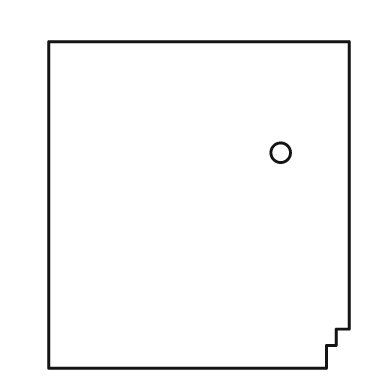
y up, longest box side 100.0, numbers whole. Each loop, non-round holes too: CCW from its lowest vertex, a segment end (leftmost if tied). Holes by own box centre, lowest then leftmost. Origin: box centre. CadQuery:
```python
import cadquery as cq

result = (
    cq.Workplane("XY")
    .moveTo(-46.0, -50.0)
    .lineTo(39.0, -50.0)
    .lineTo(39.0, -43.0)
    .lineTo(42.0, -43.0)
    .lineTo(42.0, -38.0)
    .lineTo(46.0, -38.0)
    .lineTo(46.0, 50.0)
    .lineTo(-46.0, 50.0)
    .close()
    .moveTo(25.0, 16.0)
    .circle(3.0)
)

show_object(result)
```